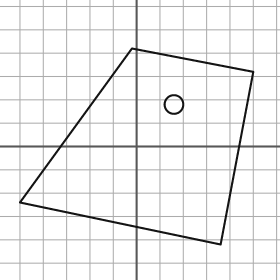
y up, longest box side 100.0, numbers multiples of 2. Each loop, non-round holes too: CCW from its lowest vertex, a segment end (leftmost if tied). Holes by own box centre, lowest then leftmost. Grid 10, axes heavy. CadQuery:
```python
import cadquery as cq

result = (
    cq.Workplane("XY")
    .moveTo(36.0, -42.0)
    .lineTo(50.0, 32.0)
    .lineTo(-2.0, 42.0)
    .lineTo(-50.0, -24.0)
    .close()
    .moveTo(16.0, 18.0)
    .circle(4.0)
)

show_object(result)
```